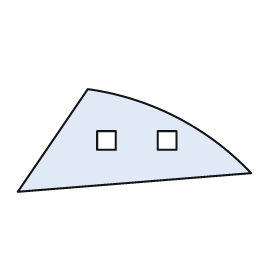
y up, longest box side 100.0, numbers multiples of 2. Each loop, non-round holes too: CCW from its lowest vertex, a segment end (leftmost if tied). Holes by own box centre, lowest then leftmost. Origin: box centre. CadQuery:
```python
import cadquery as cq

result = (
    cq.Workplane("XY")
    .moveTo(-50.0, -22.0)
    .lineTo(50.0, -14.0)
    .threePointArc((18.0, 10.0), (-20.0, 22.0))
    .close()
    .moveTo(-16.0, -4.0)
    .lineTo(-8.0, -4.0)
    .lineTo(-8.0, 4.0)
    .lineTo(-16.0, 4.0)
    .close()
    .moveTo(10.0, -4.0)
    .lineTo(18.0, -4.0)
    .lineTo(18.0, 4.0)
    .lineTo(10.0, 4.0)
    .close()
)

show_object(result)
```